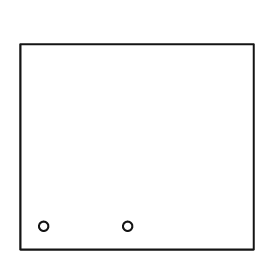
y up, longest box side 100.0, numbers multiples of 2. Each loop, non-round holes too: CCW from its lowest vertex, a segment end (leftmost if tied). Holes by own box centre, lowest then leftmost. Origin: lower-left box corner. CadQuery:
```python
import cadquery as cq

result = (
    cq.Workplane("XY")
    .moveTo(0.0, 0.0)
    .lineTo(100.0, 0.0)
    .lineTo(100.0, 88.0)
    .lineTo(0.0, 88.0)
    .close()
    .moveTo(10.0, 10.0)
    .circle(2.0)
    .moveTo(46.0, 10.0)
    .circle(2.0)
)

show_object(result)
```